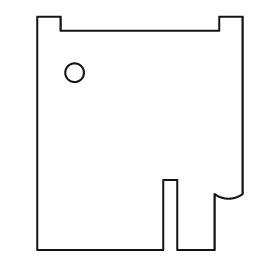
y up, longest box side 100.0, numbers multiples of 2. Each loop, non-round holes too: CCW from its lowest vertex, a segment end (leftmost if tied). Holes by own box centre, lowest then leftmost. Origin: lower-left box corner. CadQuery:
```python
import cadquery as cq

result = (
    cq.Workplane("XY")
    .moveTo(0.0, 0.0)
    .lineTo(54.0, 0.0)
    .lineTo(54.0, 30.0)
    .lineTo(60.0, 30.0)
    .lineTo(60.0, 0.0)
    .lineTo(76.0, 0.0)
    .lineTo(76.0, 24.0)
    .threePointArc((82.0, 22.0), (88.0, 24.0))
    .lineTo(88.0, 100.0)
    .lineTo(78.0, 100.0)
    .lineTo(78.0, 94.0)
    .lineTo(10.0, 94.0)
    .lineTo(10.0, 100.0)
    .lineTo(0.0, 100.0)
    .close()
    .moveTo(16.0, 76.0)
    .circle(4.0)
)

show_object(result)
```